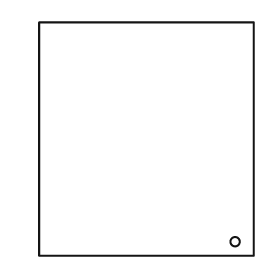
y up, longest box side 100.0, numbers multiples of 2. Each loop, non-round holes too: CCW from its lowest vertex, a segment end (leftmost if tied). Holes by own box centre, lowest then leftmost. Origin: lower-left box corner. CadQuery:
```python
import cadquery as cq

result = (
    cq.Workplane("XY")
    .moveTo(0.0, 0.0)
    .lineTo(92.0, 0.0)
    .lineTo(92.0, 100.0)
    .lineTo(0.0, 100.0)
    .close()
    .moveTo(84.0, 6.0)
    .circle(2.0)
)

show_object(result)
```